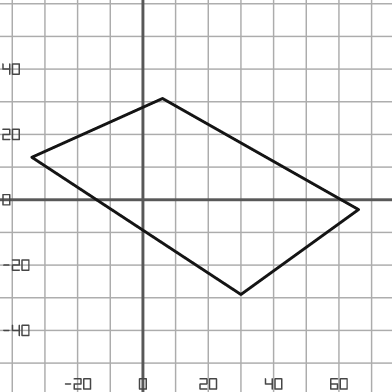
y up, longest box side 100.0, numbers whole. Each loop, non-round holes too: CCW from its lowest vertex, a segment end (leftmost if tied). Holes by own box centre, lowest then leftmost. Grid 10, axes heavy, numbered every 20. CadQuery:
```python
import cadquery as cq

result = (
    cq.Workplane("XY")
    .moveTo(30.0, -29.0)
    .lineTo(66.0, -3.0)
    .lineTo(6.0, 31.0)
    .lineTo(-34.0, 13.0)
    .close()
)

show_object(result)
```